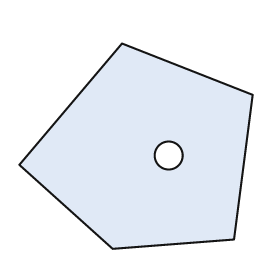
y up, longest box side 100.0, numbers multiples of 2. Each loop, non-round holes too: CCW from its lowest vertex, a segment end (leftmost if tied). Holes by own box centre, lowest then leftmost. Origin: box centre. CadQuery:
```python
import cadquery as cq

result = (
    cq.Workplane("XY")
    .moveTo(-10.0, -44.0)
    .lineTo(42.0, -40.0)
    .lineTo(50.0, 22.0)
    .lineTo(-6.0, 44.0)
    .lineTo(-50.0, -8.0)
    .close()
    .moveTo(14.0, -4.0)
    .circle(6.0)
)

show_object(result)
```